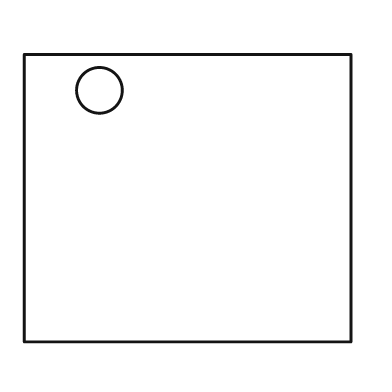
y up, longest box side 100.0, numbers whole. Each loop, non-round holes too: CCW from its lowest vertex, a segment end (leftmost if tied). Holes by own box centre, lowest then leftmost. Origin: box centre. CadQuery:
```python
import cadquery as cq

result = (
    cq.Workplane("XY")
    .moveTo(-50.0, -44.0)
    .lineTo(50.0, -44.0)
    .lineTo(50.0, 44.0)
    .lineTo(-50.0, 44.0)
    .close()
    .moveTo(-27.0, 33.0)
    .circle(7.0)
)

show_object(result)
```